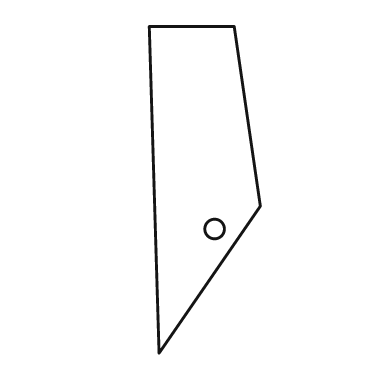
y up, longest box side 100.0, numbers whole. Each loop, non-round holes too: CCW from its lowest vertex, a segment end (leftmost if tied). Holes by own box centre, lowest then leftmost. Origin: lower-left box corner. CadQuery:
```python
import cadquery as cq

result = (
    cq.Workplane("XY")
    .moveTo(3.0, 0.0)
    .lineTo(34.0, 45.0)
    .lineTo(26.0, 100.0)
    .lineTo(0.0, 100.0)
    .close()
    .moveTo(20.0, 38.0)
    .circle(3.0)
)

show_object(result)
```